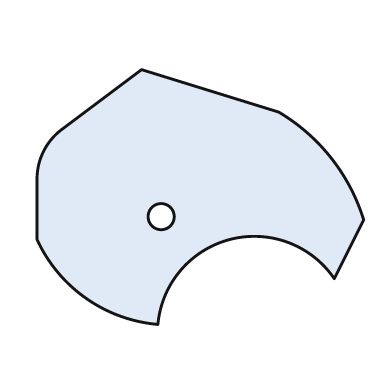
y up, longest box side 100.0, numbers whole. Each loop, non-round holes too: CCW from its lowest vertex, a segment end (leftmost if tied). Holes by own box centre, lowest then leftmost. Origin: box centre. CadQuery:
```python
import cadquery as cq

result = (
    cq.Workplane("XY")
    .moveTo(-13.0, -39.0)
    .threePointArc((9.0, -13.0), (41.0, -25.0))
    .lineTo(50.0, -7.0)
    .threePointArc((40.0, 12.0), (24.0, 26.0))
    .lineTo(-18.0, 39.0)
    .lineTo(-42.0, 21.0)
    .threePointArc((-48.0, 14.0), (-50.0, 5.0))
    .lineTo(-50.0, -13.0)
    .threePointArc((-35.0, -31.0), (-13.0, -39.0))
    .close()
    .moveTo(-12.0, -6.0)
    .circle(4.0)
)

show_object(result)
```